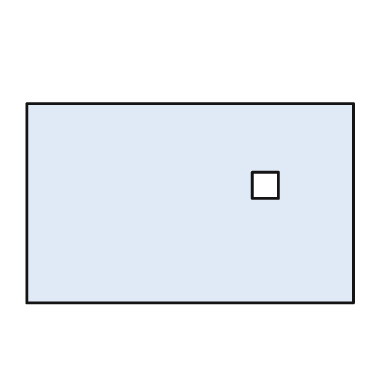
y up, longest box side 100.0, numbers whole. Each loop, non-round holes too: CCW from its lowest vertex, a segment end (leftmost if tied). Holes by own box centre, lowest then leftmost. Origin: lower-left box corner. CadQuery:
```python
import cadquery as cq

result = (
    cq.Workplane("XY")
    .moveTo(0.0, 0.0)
    .lineTo(100.0, 0.0)
    .lineTo(100.0, 61.0)
    .lineTo(0.0, 61.0)
    .close()
    .moveTo(69.0, 32.0)
    .lineTo(77.0, 32.0)
    .lineTo(77.0, 40.0)
    .lineTo(69.0, 40.0)
    .close()
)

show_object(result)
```